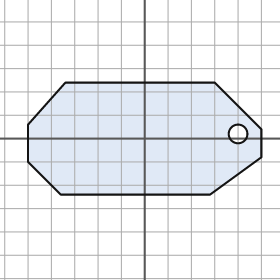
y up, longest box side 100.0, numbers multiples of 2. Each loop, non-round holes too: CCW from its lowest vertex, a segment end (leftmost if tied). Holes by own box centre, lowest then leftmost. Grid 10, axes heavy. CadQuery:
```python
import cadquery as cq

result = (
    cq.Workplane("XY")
    .moveTo(-36.0, -24.0)
    .lineTo(28.0, -24.0)
    .lineTo(50.0, -8.0)
    .lineTo(50.0, 4.0)
    .lineTo(30.0, 24.0)
    .lineTo(-34.0, 24.0)
    .lineTo(-50.0, 6.0)
    .lineTo(-50.0, -10.0)
    .close()
    .moveTo(40.0, 2.0)
    .circle(4.0)
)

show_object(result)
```